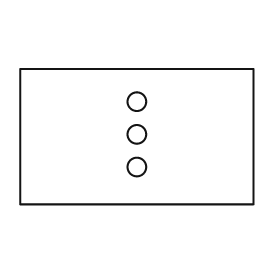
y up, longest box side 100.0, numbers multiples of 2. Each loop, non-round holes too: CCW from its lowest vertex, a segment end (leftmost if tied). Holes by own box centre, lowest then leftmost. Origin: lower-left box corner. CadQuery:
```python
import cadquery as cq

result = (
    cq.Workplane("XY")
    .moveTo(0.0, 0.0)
    .lineTo(100.0, 0.0)
    .lineTo(100.0, 58.0)
    .lineTo(0.0, 58.0)
    .close()
    .moveTo(50.0, 16.0)
    .circle(4.0)
    .moveTo(50.0, 30.0)
    .circle(4.0)
    .moveTo(50.0, 44.0)
    .circle(4.0)
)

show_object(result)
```